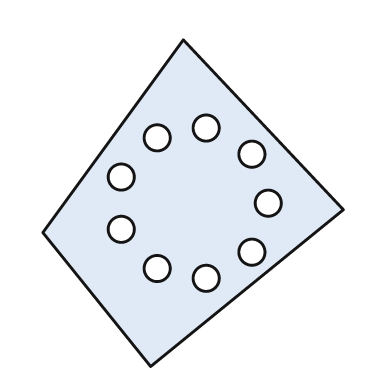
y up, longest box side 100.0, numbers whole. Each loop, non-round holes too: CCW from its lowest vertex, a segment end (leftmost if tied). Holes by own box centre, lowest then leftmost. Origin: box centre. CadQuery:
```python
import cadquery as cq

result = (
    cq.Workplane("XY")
    .moveTo(-13.0, -50.0)
    .lineTo(46.0, -2.0)
    .lineTo(-3.0, 50.0)
    .lineTo(-46.0, -9.0)
    .close()
    .moveTo(4.0, -23.0)
    .circle(4.0)
    .moveTo(-11.0, -20.0)
    .circle(4.0)
    .moveTo(18.0, -15.0)
    .circle(4.0)
    .moveTo(-22.0, -8.0)
    .circle(4.0)
    .moveTo(23.0, 0.0)
    .circle(4.0)
    .moveTo(-22.0, 8.0)
    .circle(4.0)
    .moveTo(18.0, 15.0)
    .circle(4.0)
    .moveTo(-11.0, 20.0)
    .circle(4.0)
    .moveTo(4.0, 23.0)
    .circle(4.0)
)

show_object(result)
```